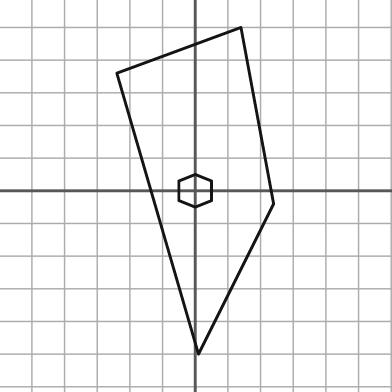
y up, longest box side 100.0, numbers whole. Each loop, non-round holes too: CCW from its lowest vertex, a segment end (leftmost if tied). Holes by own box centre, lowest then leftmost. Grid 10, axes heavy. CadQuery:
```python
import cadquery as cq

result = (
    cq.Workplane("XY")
    .moveTo(1.0, -50.0)
    .lineTo(24.0, -4.0)
    .lineTo(14.0, 50.0)
    .lineTo(-24.0, 36.0)
    .close()
    .moveTo(0.0, -5.0)
    .lineTo(5.0, -3.0)
    .lineTo(5.0, 3.0)
    .lineTo(0.0, 5.0)
    .lineTo(-5.0, 3.0)
    .lineTo(-5.0, -3.0)
    .close()
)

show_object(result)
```